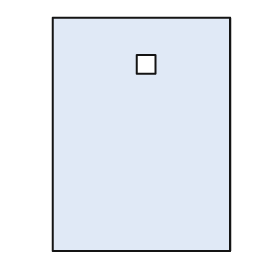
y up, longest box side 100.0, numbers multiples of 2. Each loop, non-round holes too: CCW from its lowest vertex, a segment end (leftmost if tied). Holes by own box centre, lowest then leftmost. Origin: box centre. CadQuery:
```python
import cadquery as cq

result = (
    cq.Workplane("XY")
    .moveTo(-38.0, -50.0)
    .lineTo(38.0, -50.0)
    .lineTo(38.0, 50.0)
    .lineTo(-38.0, 50.0)
    .close()
    .moveTo(-2.0, 26.0)
    .lineTo(6.0, 26.0)
    .lineTo(6.0, 34.0)
    .lineTo(-2.0, 34.0)
    .close()
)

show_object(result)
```